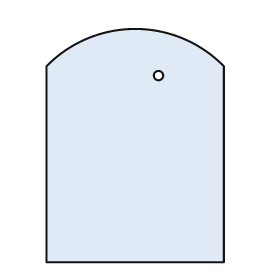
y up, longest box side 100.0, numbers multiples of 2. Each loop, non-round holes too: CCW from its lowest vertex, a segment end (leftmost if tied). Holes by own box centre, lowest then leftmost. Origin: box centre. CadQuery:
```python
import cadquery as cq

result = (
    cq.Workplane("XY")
    .moveTo(-38.0, -50.0)
    .lineTo(38.0, -50.0)
    .lineTo(38.0, 34.0)
    .threePointArc((0.0, 50.0), (-38.0, 34.0))
    .close()
    .moveTo(10.0, 30.0)
    .circle(2.0)
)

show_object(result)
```